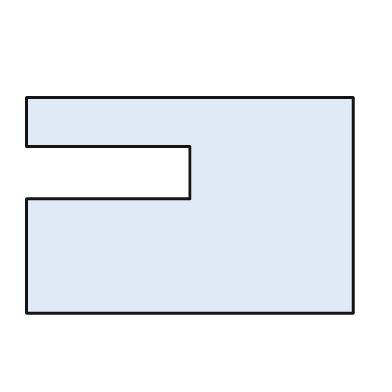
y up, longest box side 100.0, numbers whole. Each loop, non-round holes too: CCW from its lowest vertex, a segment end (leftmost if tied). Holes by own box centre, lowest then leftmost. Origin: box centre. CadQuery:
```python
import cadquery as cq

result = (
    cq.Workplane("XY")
    .moveTo(-50.0, -33.0)
    .lineTo(50.0, -33.0)
    .lineTo(50.0, 33.0)
    .lineTo(-50.0, 33.0)
    .lineTo(-50.0, 18.0)
    .lineTo(0.0, 18.0)
    .lineTo(0.0, 2.0)
    .lineTo(-50.0, 2.0)
    .close()
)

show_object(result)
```